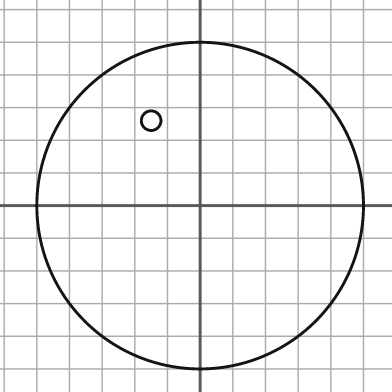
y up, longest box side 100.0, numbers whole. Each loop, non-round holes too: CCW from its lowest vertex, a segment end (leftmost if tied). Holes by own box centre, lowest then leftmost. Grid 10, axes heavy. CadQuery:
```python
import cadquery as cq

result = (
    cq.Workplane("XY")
    .moveTo(0.0, 0.0)
    .circle(50.0)
    .moveTo(-15.0, 26.0)
    .circle(3.0)
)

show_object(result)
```